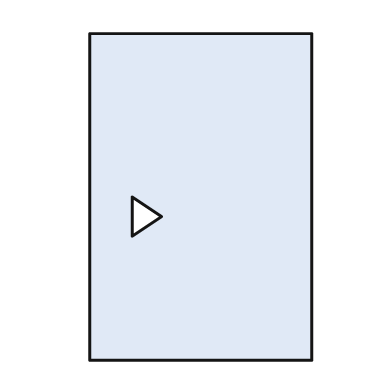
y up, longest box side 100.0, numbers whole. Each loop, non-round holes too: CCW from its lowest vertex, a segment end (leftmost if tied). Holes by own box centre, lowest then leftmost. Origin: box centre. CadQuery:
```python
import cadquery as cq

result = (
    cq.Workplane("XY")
    .moveTo(-34.0, -50.0)
    .lineTo(34.0, -50.0)
    .lineTo(34.0, 50.0)
    .lineTo(-34.0, 50.0)
    .close()
    .moveTo(-21.0, -12.0)
    .lineTo(-12.0, -6.0)
    .lineTo(-21.0, 0.0)
    .close()
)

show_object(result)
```